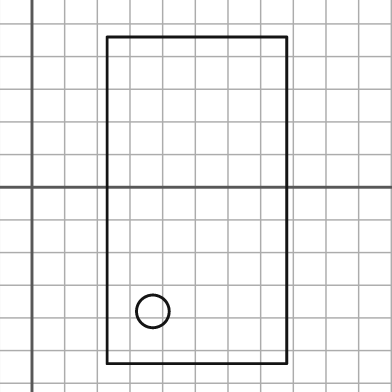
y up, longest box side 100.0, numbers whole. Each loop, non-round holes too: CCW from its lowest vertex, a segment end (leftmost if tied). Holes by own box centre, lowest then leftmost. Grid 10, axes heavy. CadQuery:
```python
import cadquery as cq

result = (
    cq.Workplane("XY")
    .moveTo(23.0, -54.0)
    .lineTo(78.0, -54.0)
    .lineTo(78.0, 46.0)
    .lineTo(23.0, 46.0)
    .close()
    .moveTo(37.0, -38.0)
    .circle(5.0)
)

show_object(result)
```